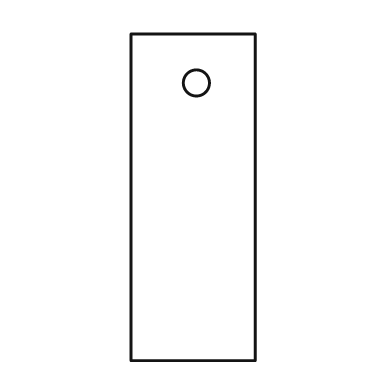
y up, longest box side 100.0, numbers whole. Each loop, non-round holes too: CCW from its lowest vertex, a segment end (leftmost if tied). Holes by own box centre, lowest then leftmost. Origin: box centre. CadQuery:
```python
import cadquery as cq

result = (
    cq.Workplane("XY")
    .moveTo(-19.0, -50.0)
    .lineTo(19.0, -50.0)
    .lineTo(19.0, 50.0)
    .lineTo(-19.0, 50.0)
    .close()
    .moveTo(1.0, 35.0)
    .circle(4.0)
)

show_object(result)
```